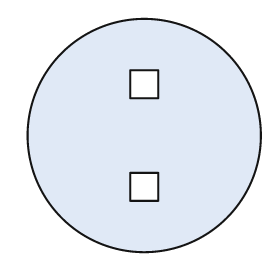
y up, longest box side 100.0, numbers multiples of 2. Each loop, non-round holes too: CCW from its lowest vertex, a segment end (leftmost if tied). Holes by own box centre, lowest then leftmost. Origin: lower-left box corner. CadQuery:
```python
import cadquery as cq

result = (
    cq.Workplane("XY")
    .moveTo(50.0, 50.0)
    .circle(50.0)
    .moveTo(44.0, 22.0)
    .lineTo(56.0, 22.0)
    .lineTo(56.0, 34.0)
    .lineTo(44.0, 34.0)
    .close()
    .moveTo(44.0, 66.0)
    .lineTo(56.0, 66.0)
    .lineTo(56.0, 78.0)
    .lineTo(44.0, 78.0)
    .close()
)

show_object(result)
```